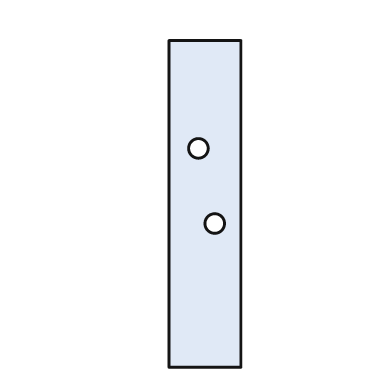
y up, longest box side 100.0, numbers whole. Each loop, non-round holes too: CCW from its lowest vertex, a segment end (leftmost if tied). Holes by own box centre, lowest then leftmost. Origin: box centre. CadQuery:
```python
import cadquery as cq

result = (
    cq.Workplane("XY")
    .moveTo(-11.0, -50.0)
    .lineTo(11.0, -50.0)
    .lineTo(11.0, 50.0)
    .lineTo(-11.0, 50.0)
    .close()
    .moveTo(3.0, -6.0)
    .circle(3.0)
    .moveTo(-2.0, 17.0)
    .circle(3.0)
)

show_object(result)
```